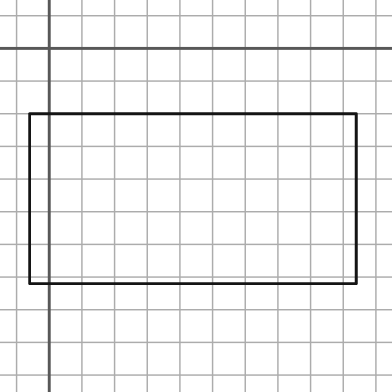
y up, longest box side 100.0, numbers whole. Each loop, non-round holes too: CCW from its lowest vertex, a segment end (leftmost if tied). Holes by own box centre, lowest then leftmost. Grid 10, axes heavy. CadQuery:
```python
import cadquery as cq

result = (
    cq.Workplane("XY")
    .moveTo(-6.0, -72.0)
    .lineTo(94.0, -72.0)
    .lineTo(94.0, -20.0)
    .lineTo(-6.0, -20.0)
    .close()
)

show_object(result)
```